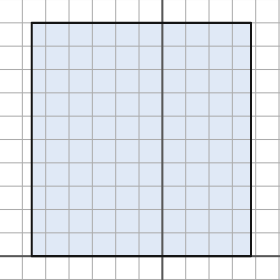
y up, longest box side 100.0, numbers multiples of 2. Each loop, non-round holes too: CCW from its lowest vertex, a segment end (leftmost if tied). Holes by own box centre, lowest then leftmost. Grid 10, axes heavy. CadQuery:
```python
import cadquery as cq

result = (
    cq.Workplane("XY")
    .moveTo(-56.0, 0.0)
    .lineTo(38.0, 0.0)
    .lineTo(38.0, 100.0)
    .lineTo(-56.0, 100.0)
    .close()
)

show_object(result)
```